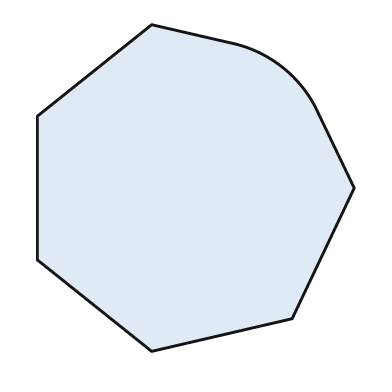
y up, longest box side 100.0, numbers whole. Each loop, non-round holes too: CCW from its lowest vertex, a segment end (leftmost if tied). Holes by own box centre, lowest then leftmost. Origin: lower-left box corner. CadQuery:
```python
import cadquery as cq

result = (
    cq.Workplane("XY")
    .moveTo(35.0, 0.0)
    .lineTo(78.0, 10.0)
    .lineTo(97.0, 50.0)
    .lineTo(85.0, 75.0)
    .threePointArc((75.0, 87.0), (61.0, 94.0))
    .lineTo(35.0, 100.0)
    .lineTo(0.0, 72.0)
    .lineTo(0.0, 28.0)
    .close()
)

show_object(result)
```